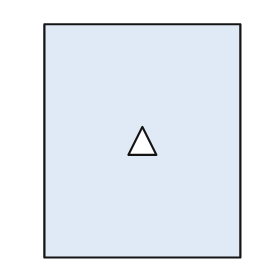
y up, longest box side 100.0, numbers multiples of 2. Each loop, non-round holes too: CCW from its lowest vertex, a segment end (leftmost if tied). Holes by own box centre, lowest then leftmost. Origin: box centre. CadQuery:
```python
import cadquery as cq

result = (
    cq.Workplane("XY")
    .moveTo(-42.0, -50.0)
    .lineTo(42.0, -50.0)
    .lineTo(42.0, 50.0)
    .lineTo(-42.0, 50.0)
    .close()
    .moveTo(-6.0, -6.0)
    .lineTo(6.0, -6.0)
    .lineTo(0.0, 6.0)
    .close()
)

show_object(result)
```